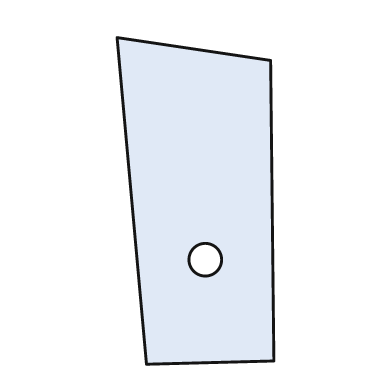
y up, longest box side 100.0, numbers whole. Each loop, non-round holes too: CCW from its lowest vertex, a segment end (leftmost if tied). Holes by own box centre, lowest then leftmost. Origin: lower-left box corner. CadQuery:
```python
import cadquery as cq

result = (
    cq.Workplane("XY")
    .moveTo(9.0, 0.0)
    .lineTo(48.0, 1.0)
    .lineTo(47.0, 93.0)
    .lineTo(0.0, 100.0)
    .close()
    .moveTo(27.0, 32.0)
    .circle(5.0)
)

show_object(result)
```